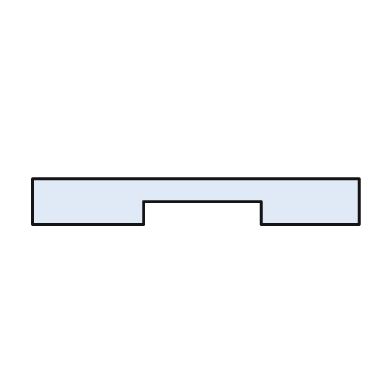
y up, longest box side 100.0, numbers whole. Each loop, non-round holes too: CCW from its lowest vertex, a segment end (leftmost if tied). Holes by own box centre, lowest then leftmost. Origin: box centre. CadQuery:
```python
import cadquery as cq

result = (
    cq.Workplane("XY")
    .moveTo(-50.0, -7.0)
    .lineTo(-16.0, -7.0)
    .lineTo(-16.0, 0.0)
    .lineTo(20.0, 0.0)
    .lineTo(20.0, -7.0)
    .lineTo(50.0, -7.0)
    .lineTo(50.0, 7.0)
    .lineTo(-50.0, 7.0)
    .close()
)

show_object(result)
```